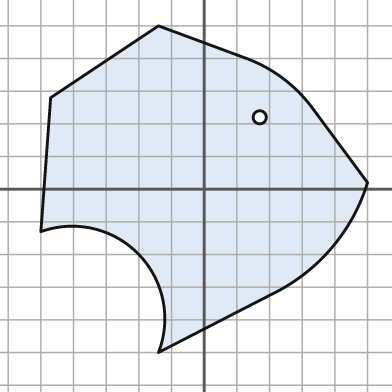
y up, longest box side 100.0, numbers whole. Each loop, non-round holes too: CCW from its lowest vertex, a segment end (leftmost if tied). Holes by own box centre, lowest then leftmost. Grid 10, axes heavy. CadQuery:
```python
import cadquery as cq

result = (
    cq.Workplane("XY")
    .moveTo(-14.0, -50.0)
    .lineTo(21.0, -32.0)
    .threePointArc((39.0, -18.0), (50.0, 2.0))
    .lineTo(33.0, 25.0)
    .threePointArc((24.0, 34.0), (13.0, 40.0))
    .lineTo(-14.0, 50.0)
    .lineTo(-47.0, 28.0)
    .lineTo(-50.0, -13.0)
    .threePointArc((-20.0, -20.0), (-14.0, -50.0))
    .close()
    .moveTo(17.0, 22.0)
    .circle(2.0)
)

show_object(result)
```